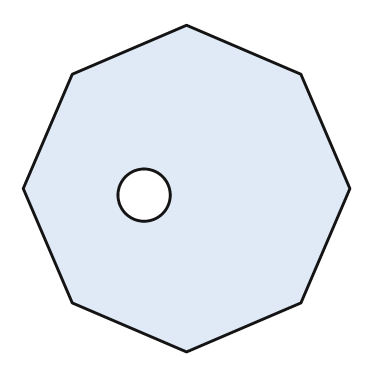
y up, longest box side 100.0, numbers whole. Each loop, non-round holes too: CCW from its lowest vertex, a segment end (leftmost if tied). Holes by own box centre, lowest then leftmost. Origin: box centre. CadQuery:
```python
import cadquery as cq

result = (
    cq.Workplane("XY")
    .moveTo(0.0, -50.0)
    .lineTo(35.0, -35.0)
    .lineTo(50.0, 0.0)
    .lineTo(35.0, 35.0)
    .lineTo(0.0, 50.0)
    .lineTo(-35.0, 35.0)
    .lineTo(-50.0, 0.0)
    .lineTo(-35.0, -35.0)
    .close()
    .moveTo(-13.0, -2.0)
    .circle(8.0)
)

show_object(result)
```